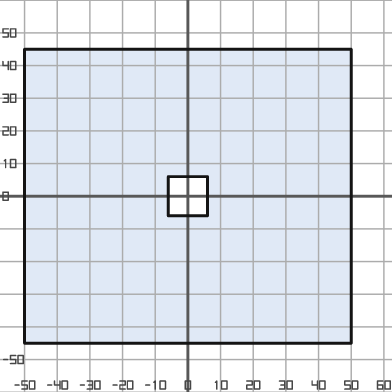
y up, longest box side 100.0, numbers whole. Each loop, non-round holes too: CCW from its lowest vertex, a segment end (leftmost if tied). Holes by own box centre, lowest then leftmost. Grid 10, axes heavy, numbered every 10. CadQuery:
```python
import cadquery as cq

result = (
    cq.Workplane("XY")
    .moveTo(-50.0, -45.0)
    .lineTo(50.0, -45.0)
    .lineTo(50.0, 45.0)
    .lineTo(-50.0, 45.0)
    .close()
    .moveTo(-6.0, -6.0)
    .lineTo(6.0, -6.0)
    .lineTo(6.0, 6.0)
    .lineTo(-6.0, 6.0)
    .close()
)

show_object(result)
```